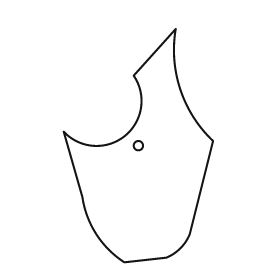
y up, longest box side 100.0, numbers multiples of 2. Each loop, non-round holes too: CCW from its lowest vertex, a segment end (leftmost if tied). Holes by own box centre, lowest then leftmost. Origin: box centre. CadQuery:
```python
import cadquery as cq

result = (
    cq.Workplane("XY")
    .moveTo(-6.0, -50.0)
    .lineTo(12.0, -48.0)
    .threePointArc((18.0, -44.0), (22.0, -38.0))
    .lineTo(32.0, 2.0)
    .threePointArc((18.0, 24.0), (16.0, 50.0))
    .lineTo(-2.0, 30.0)
    .threePointArc((-6.0, 4.0), (-32.0, 6.0))
    .lineTo(-24.0, -22.0)
    .threePointArc((-18.0, -38.0), (-6.0, -50.0))
    .close()
    .moveTo(0.0, 0.0)
    .circle(2.0)
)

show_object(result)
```